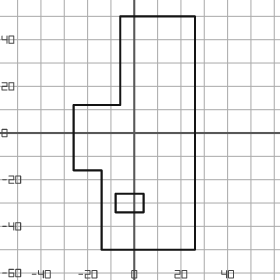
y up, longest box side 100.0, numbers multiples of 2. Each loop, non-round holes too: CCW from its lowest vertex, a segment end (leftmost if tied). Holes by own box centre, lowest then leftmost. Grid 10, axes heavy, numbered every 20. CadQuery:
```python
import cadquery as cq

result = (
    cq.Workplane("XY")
    .moveTo(-14.0, -50.0)
    .lineTo(26.0, -50.0)
    .lineTo(26.0, 50.0)
    .lineTo(-6.0, 50.0)
    .lineTo(-6.0, 12.0)
    .lineTo(-26.0, 12.0)
    .lineTo(-26.0, -16.0)
    .lineTo(-14.0, -16.0)
    .close()
    .moveTo(-8.0, -34.0)
    .lineTo(4.0, -34.0)
    .lineTo(4.0, -26.0)
    .lineTo(-8.0, -26.0)
    .close()
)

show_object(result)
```